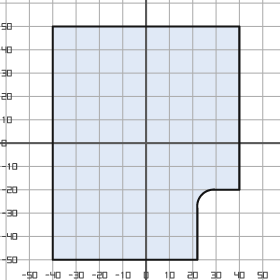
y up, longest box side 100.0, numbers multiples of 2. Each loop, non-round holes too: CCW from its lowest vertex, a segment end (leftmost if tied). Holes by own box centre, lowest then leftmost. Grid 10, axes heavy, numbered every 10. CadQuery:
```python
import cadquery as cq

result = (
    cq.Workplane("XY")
    .moveTo(-40.0, -50.0)
    .lineTo(22.0, -50.0)
    .lineTo(22.0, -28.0)
    .threePointArc((24.0, -22.0), (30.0, -20.0))
    .lineTo(40.0, -20.0)
    .lineTo(40.0, 50.0)
    .lineTo(-40.0, 50.0)
    .close()
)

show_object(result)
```